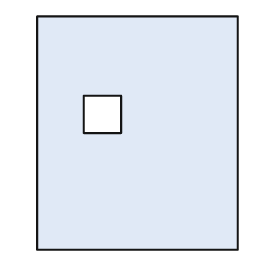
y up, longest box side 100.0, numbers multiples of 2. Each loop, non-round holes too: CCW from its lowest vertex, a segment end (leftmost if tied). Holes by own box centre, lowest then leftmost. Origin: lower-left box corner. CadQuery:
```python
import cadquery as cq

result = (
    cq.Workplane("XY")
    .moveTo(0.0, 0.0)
    .lineTo(86.0, 0.0)
    .lineTo(86.0, 100.0)
    .lineTo(0.0, 100.0)
    .close()
    .moveTo(20.0, 50.0)
    .lineTo(36.0, 50.0)
    .lineTo(36.0, 66.0)
    .lineTo(20.0, 66.0)
    .close()
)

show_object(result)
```